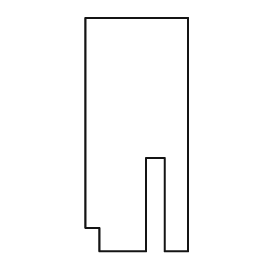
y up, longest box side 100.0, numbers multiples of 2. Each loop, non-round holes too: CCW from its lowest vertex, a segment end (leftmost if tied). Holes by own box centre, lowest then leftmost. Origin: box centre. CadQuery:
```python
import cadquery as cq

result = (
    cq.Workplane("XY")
    .moveTo(-16.0, -50.0)
    .lineTo(4.0, -50.0)
    .lineTo(4.0, -10.0)
    .lineTo(12.0, -10.0)
    .lineTo(12.0, -50.0)
    .lineTo(22.0, -50.0)
    .lineTo(22.0, 50.0)
    .lineTo(-22.0, 50.0)
    .lineTo(-22.0, -40.0)
    .lineTo(-16.0, -40.0)
    .close()
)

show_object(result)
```